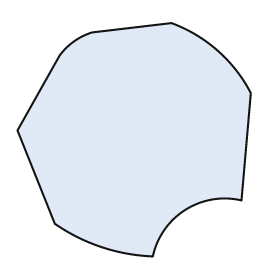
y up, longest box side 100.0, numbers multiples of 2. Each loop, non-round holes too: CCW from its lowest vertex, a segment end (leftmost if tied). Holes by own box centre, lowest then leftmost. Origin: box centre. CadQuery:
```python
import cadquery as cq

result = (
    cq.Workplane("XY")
    .moveTo(8.0, -50.0)
    .threePointArc((22.0, -30.0), (46.0, -26.0))
    .lineTo(50.0, 20.0)
    .threePointArc((36.0, 38.0), (16.0, 50.0))
    .lineTo(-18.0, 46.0)
    .threePointArc((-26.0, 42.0), (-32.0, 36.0))
    .lineTo(-50.0, 4.0)
    .lineTo(-34.0, -36.0)
    .threePointArc((-14.0, -46.0), (8.0, -50.0))
    .close()
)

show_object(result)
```